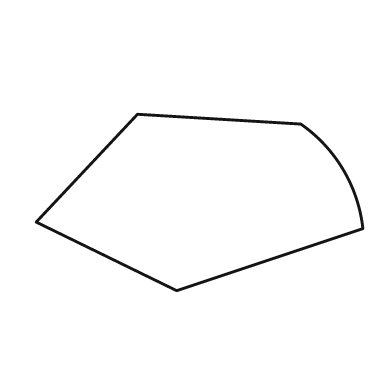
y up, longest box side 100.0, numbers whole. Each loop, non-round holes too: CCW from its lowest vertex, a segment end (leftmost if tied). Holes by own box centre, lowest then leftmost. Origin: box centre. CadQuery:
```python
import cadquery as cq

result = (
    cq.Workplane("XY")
    .moveTo(-7.0, -27.0)
    .lineTo(50.0, -8.0)
    .threePointArc((44.0, 10.0), (31.0, 24.0))
    .lineTo(-19.0, 27.0)
    .lineTo(-50.0, -6.0)
    .close()
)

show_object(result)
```